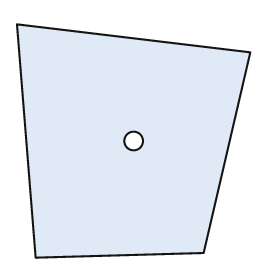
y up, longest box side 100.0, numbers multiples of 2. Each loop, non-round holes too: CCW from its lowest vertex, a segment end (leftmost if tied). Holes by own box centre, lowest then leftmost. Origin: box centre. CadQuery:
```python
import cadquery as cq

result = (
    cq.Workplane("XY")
    .moveTo(-42.0, -50.0)
    .lineTo(30.0, -48.0)
    .lineTo(50.0, 38.0)
    .lineTo(-50.0, 50.0)
    .close()
    .moveTo(0.0, 0.0)
    .circle(4.0)
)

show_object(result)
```